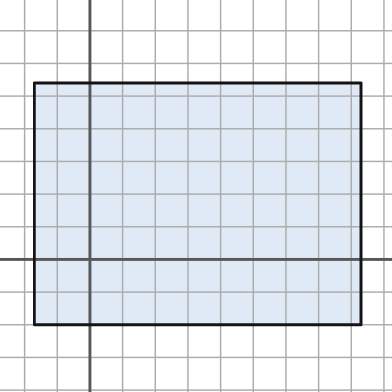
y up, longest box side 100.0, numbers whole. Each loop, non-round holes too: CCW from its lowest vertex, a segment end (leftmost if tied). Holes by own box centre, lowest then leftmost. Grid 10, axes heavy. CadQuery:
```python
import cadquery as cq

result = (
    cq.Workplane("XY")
    .moveTo(-17.0, -20.0)
    .lineTo(83.0, -20.0)
    .lineTo(83.0, 54.0)
    .lineTo(-17.0, 54.0)
    .close()
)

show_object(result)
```